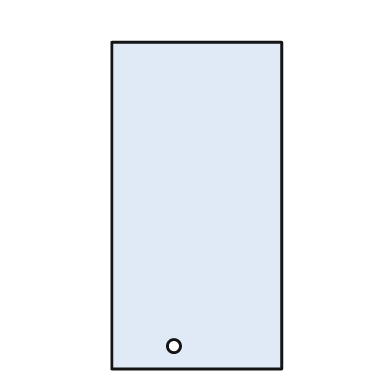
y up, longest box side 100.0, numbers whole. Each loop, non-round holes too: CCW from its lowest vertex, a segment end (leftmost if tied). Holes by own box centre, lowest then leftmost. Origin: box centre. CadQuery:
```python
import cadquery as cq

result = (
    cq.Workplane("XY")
    .moveTo(-26.0, -50.0)
    .lineTo(26.0, -50.0)
    .lineTo(26.0, 50.0)
    .lineTo(-26.0, 50.0)
    .close()
    .moveTo(-7.0, -43.0)
    .circle(2.0)
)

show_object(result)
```